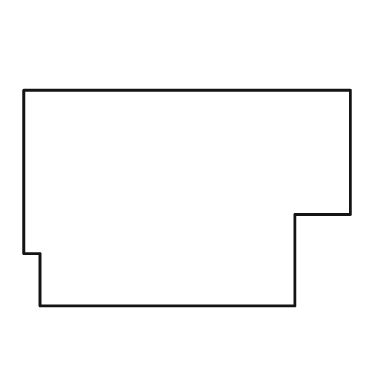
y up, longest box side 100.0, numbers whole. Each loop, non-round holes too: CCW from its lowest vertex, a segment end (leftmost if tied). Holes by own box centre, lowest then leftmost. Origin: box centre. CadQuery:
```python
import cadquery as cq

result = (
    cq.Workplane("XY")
    .moveTo(-45.0, -33.0)
    .lineTo(33.0, -33.0)
    .lineTo(33.0, -5.0)
    .lineTo(50.0, -5.0)
    .lineTo(50.0, 33.0)
    .lineTo(-50.0, 33.0)
    .lineTo(-50.0, -17.0)
    .lineTo(-45.0, -17.0)
    .close()
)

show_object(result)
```